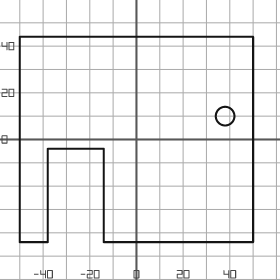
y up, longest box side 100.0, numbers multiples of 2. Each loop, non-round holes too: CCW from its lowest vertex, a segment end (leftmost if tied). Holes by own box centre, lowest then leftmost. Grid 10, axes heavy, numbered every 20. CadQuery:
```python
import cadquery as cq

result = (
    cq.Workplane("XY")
    .moveTo(-50.0, -44.0)
    .lineTo(-38.0, -44.0)
    .lineTo(-38.0, -4.0)
    .lineTo(-14.0, -4.0)
    .lineTo(-14.0, -44.0)
    .lineTo(50.0, -44.0)
    .lineTo(50.0, 44.0)
    .lineTo(-50.0, 44.0)
    .close()
    .moveTo(38.0, 10.0)
    .circle(4.0)
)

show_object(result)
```